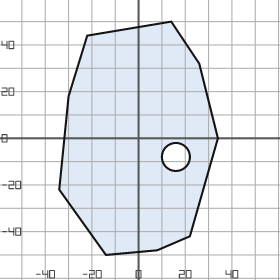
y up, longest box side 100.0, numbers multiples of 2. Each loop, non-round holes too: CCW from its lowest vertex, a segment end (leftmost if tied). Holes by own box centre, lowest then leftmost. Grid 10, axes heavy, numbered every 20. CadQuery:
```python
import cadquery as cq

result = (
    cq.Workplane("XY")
    .moveTo(-14.0, -50.0)
    .lineTo(8.0, -48.0)
    .lineTo(22.0, -42.0)
    .lineTo(34.0, 0.0)
    .lineTo(26.0, 32.0)
    .lineTo(14.0, 50.0)
    .lineTo(-22.0, 44.0)
    .lineTo(-30.0, 18.0)
    .lineTo(-34.0, -22.0)
    .close()
    .moveTo(16.0, -8.0)
    .circle(6.0)
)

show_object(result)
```